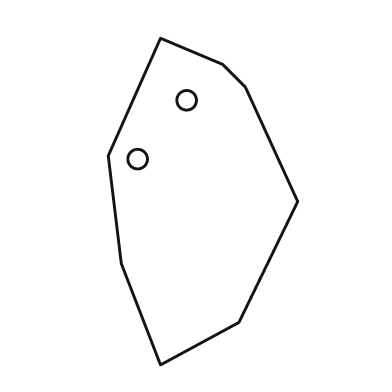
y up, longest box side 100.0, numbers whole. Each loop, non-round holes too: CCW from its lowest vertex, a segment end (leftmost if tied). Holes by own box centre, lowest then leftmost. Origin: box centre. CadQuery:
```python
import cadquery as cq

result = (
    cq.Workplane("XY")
    .moveTo(-13.0, -50.0)
    .lineTo(11.0, -37.0)
    .lineTo(29.0, 0.0)
    .lineTo(13.0, 35.0)
    .lineTo(6.0, 42.0)
    .lineTo(-13.0, 50.0)
    .lineTo(-29.0, 14.0)
    .lineTo(-25.0, -19.0)
    .close()
    .moveTo(-20.0, 13.0)
    .circle(3.0)
    .moveTo(-5.0, 31.0)
    .circle(3.0)
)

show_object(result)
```